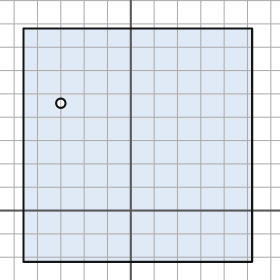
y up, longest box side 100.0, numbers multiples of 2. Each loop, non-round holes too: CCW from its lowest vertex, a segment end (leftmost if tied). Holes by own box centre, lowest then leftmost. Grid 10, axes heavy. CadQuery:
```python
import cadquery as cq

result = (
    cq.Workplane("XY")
    .moveTo(-46.0, -22.0)
    .lineTo(52.0, -22.0)
    .lineTo(52.0, 78.0)
    .lineTo(-46.0, 78.0)
    .close()
    .moveTo(-30.0, 46.0)
    .circle(2.0)
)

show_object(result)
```